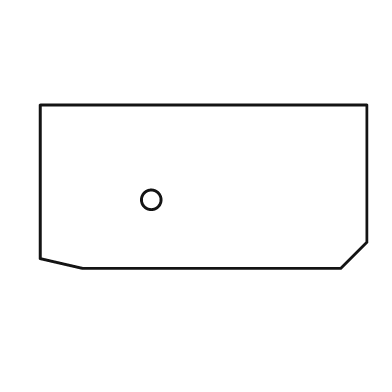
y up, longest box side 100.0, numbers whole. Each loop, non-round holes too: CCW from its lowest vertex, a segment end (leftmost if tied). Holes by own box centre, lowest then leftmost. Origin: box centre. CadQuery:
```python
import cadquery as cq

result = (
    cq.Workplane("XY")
    .moveTo(-37.0, -25.0)
    .lineTo(42.0, -25.0)
    .lineTo(50.0, -17.0)
    .lineTo(50.0, 25.0)
    .lineTo(-50.0, 25.0)
    .lineTo(-50.0, -22.0)
    .close()
    .moveTo(-16.0, -4.0)
    .circle(3.0)
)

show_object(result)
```